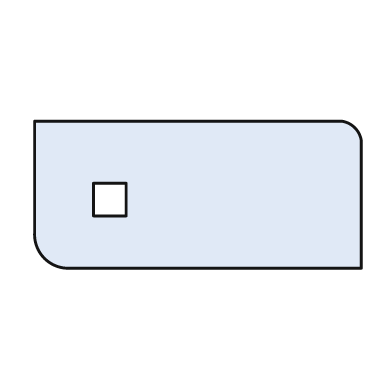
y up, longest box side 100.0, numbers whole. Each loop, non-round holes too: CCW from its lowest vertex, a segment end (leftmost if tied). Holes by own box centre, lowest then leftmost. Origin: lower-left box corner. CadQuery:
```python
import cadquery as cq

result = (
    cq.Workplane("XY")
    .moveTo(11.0, 0.0)
    .lineTo(100.0, 0.0)
    .lineTo(100.0, 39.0)
    .threePointArc((98.0, 43.0), (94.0, 45.0))
    .lineTo(0.0, 45.0)
    .lineTo(0.0, 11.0)
    .threePointArc((3.0, 3.0), (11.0, 0.0))
    .close()
    .moveTo(18.0, 16.0)
    .lineTo(28.0, 16.0)
    .lineTo(28.0, 26.0)
    .lineTo(18.0, 26.0)
    .close()
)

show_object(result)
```